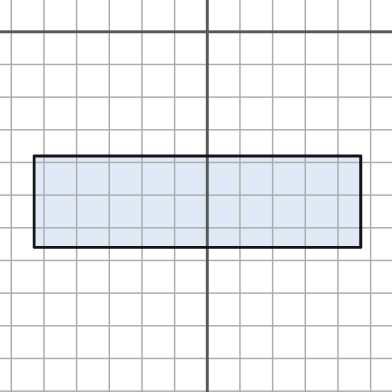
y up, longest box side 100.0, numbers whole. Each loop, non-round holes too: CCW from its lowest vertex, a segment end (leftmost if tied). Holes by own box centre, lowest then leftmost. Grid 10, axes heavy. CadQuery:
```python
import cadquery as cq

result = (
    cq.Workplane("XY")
    .moveTo(-53.0, -66.0)
    .lineTo(47.0, -66.0)
    .lineTo(47.0, -38.0)
    .lineTo(-53.0, -38.0)
    .close()
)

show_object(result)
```